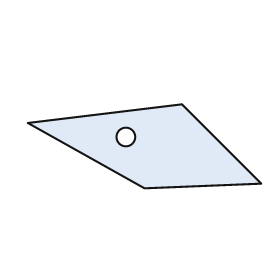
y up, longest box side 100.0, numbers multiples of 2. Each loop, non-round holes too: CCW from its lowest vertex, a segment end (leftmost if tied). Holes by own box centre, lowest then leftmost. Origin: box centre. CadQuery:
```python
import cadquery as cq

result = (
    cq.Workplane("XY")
    .moveTo(0.0, -18.0)
    .lineTo(50.0, -16.0)
    .lineTo(16.0, 18.0)
    .lineTo(-50.0, 10.0)
    .close()
    .moveTo(-8.0, 4.0)
    .circle(4.0)
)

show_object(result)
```